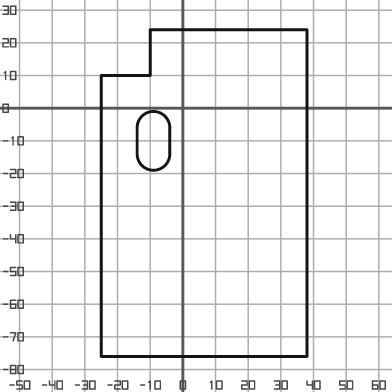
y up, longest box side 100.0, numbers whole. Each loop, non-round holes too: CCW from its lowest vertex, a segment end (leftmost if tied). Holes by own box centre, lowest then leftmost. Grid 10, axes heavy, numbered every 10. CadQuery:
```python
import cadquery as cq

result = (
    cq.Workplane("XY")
    .moveTo(-25.0, -76.0)
    .lineTo(38.0, -76.0)
    .lineTo(38.0, 24.0)
    .lineTo(-10.0, 24.0)
    .lineTo(-10.0, 10.0)
    .lineTo(-25.0, 10.0)
    .close()
    .moveTo(-14.0, -14.0)
    .threePointArc((-9.0, -19.0), (-4.0, -14.0))
    .lineTo(-4.0, -6.0)
    .threePointArc((-9.0, -1.0), (-14.0, -6.0))
    .close()
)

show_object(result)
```